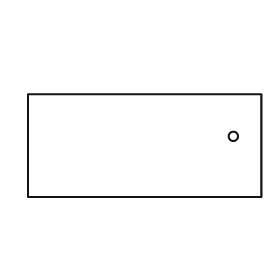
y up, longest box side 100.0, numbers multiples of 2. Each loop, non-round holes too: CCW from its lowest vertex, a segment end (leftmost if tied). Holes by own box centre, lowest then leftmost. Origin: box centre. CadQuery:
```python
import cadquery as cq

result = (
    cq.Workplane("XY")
    .moveTo(-50.0, -22.0)
    .lineTo(50.0, -22.0)
    .lineTo(50.0, 22.0)
    .lineTo(-50.0, 22.0)
    .close()
    .moveTo(38.0, 4.0)
    .circle(2.0)
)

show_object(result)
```